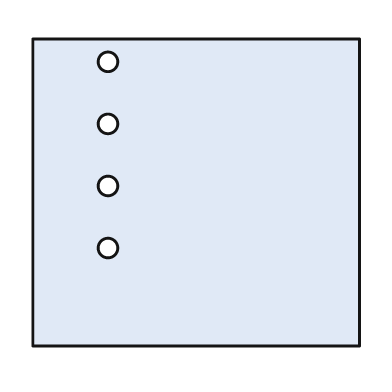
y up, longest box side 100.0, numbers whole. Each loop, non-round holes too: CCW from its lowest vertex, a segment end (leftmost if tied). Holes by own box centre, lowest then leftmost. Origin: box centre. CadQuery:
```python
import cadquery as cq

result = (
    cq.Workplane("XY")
    .moveTo(-50.0, -47.0)
    .lineTo(50.0, -47.0)
    .lineTo(50.0, 47.0)
    .lineTo(-50.0, 47.0)
    .close()
    .moveTo(-27.0, -17.0)
    .circle(3.0)
    .moveTo(-27.0, 2.0)
    .circle(3.0)
    .moveTo(-27.0, 21.0)
    .circle(3.0)
    .moveTo(-27.0, 40.0)
    .circle(3.0)
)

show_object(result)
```